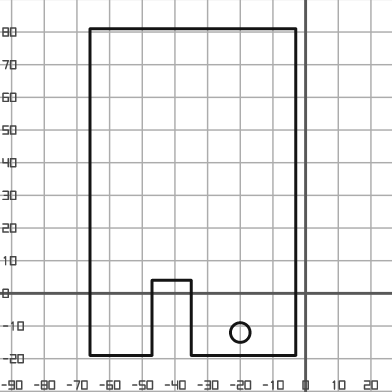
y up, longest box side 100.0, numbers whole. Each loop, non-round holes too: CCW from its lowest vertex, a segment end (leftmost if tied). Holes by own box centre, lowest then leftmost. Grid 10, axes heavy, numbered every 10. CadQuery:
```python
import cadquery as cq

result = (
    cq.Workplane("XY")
    .moveTo(-66.0, -19.0)
    .lineTo(-47.0, -19.0)
    .lineTo(-47.0, 4.0)
    .lineTo(-35.0, 4.0)
    .lineTo(-35.0, -19.0)
    .lineTo(-3.0, -19.0)
    .lineTo(-3.0, 81.0)
    .lineTo(-66.0, 81.0)
    .close()
    .moveTo(-20.0, -12.0)
    .circle(3.0)
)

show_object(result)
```